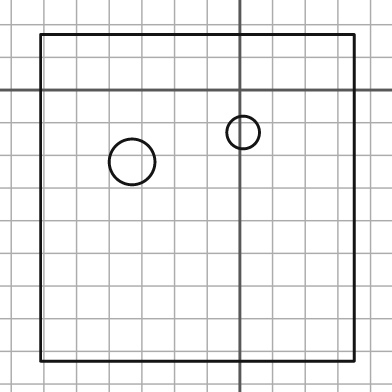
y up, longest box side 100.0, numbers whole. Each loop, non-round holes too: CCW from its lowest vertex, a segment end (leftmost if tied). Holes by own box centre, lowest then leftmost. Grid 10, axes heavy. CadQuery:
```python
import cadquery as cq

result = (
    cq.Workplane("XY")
    .moveTo(-61.0, -83.0)
    .lineTo(35.0, -83.0)
    .lineTo(35.0, 17.0)
    .lineTo(-61.0, 17.0)
    .close()
    .moveTo(-33.0, -22.0)
    .circle(7.0)
    .moveTo(1.0, -13.0)
    .circle(5.0)
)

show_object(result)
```